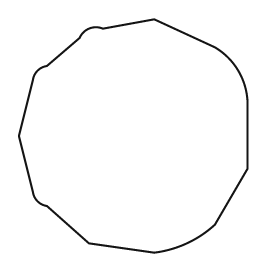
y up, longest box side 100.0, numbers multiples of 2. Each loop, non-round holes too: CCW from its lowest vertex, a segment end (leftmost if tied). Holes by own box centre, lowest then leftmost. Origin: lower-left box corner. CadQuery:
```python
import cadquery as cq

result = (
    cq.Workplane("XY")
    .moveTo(58.0, 0.0)
    .threePointArc((72.0, 4.0), (84.0, 12.0))
    .lineTo(98.0, 36.0)
    .lineTo(98.0, 64.0)
    .threePointArc((94.0, 78.0), (84.0, 88.0))
    .lineTo(58.0, 100.0)
    .lineTo(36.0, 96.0)
    .threePointArc((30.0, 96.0), (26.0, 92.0))
    .lineTo(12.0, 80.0)
    .threePointArc((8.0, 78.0), (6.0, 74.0))
    .lineTo(0.0, 50.0)
    .lineTo(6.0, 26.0)
    .threePointArc((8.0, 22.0), (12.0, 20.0))
    .lineTo(30.0, 4.0)
    .close()
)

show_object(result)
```